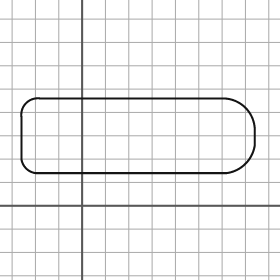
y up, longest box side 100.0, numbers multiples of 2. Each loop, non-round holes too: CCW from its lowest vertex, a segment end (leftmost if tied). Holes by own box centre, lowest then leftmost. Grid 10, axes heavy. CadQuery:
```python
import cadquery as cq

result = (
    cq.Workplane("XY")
    .moveTo(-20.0, 14.0)
    .lineTo(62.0, 14.0)
    .threePointArc((70.0, 18.0), (74.0, 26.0))
    .lineTo(74.0, 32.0)
    .threePointArc((70.0, 42.0), (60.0, 46.0))
    .lineTo(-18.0, 46.0)
    .threePointArc((-24.0, 44.0), (-26.0, 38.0))
    .lineTo(-26.0, 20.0)
    .threePointArc((-24.0, 16.0), (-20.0, 14.0))
    .close()
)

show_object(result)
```